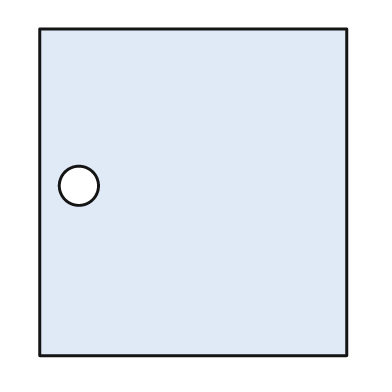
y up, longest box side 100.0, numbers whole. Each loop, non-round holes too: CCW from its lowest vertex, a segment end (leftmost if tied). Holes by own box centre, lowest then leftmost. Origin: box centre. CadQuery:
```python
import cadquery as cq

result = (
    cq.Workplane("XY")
    .moveTo(-47.0, -50.0)
    .lineTo(47.0, -50.0)
    .lineTo(47.0, 50.0)
    .lineTo(-47.0, 50.0)
    .close()
    .moveTo(-35.0, 2.0)
    .circle(6.0)
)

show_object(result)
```